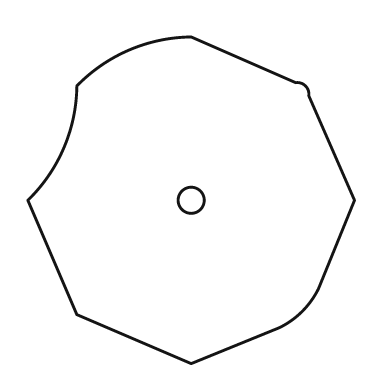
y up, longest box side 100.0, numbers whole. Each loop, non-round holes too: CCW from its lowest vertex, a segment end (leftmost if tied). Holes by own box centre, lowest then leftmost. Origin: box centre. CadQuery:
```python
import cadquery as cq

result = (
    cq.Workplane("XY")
    .moveTo(0.0, -50.0)
    .lineTo(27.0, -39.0)
    .threePointArc((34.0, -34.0), (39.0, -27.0))
    .lineTo(50.0, 0.0)
    .lineTo(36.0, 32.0)
    .threePointArc((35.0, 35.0), (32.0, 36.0))
    .lineTo(0.0, 50.0)
    .threePointArc((-19.0, 46.0), (-35.0, 35.0))
    .threePointArc((-39.0, 16.0), (-50.0, 0.0))
    .lineTo(-35.0, -35.0)
    .close()
    .moveTo(0.0, 0.0)
    .circle(4.0)
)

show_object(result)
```